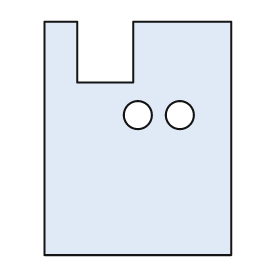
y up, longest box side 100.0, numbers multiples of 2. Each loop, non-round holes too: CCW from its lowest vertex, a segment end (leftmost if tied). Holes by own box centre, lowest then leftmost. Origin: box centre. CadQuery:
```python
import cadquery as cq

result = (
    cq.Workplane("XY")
    .moveTo(-40.0, -50.0)
    .lineTo(40.0, -50.0)
    .lineTo(40.0, 50.0)
    .lineTo(-2.0, 50.0)
    .lineTo(-2.0, 24.0)
    .lineTo(-26.0, 24.0)
    .lineTo(-26.0, 50.0)
    .lineTo(-40.0, 50.0)
    .close()
    .moveTo(0.0, 10.0)
    .circle(6.0)
    .moveTo(18.0, 10.0)
    .circle(6.0)
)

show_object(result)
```